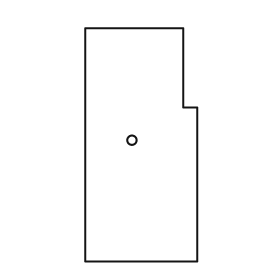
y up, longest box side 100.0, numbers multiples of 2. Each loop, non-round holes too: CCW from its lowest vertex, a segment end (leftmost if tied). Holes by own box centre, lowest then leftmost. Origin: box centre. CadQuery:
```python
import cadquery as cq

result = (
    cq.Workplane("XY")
    .moveTo(-24.0, -50.0)
    .lineTo(24.0, -50.0)
    .lineTo(24.0, 16.0)
    .lineTo(18.0, 16.0)
    .lineTo(18.0, 50.0)
    .lineTo(-24.0, 50.0)
    .close()
    .moveTo(-4.0, 2.0)
    .circle(2.0)
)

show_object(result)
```